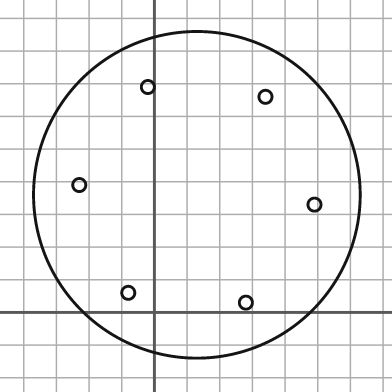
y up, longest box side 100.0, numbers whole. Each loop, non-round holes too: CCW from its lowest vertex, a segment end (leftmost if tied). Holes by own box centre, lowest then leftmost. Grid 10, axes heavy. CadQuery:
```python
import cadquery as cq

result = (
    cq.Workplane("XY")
    .moveTo(13.0, 36.0)
    .circle(50.0)
    .moveTo(28.0, 3.0)
    .circle(2.0)
    .moveTo(-8.0, 6.0)
    .circle(2.0)
    .moveTo(49.0, 33.0)
    .circle(2.0)
    .moveTo(-23.0, 39.0)
    .circle(2.0)
    .moveTo(34.0, 66.0)
    .circle(2.0)
    .moveTo(-2.0, 69.0)
    .circle(2.0)
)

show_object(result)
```